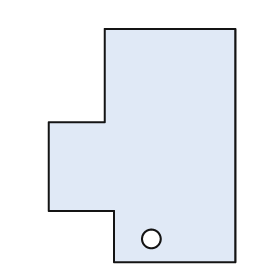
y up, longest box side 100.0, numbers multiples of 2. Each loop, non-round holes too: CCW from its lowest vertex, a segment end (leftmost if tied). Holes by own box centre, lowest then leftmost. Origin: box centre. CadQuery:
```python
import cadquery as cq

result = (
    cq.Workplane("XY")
    .moveTo(-12.0, -50.0)
    .lineTo(40.0, -50.0)
    .lineTo(40.0, 50.0)
    .lineTo(-16.0, 50.0)
    .lineTo(-16.0, 10.0)
    .lineTo(-40.0, 10.0)
    .lineTo(-40.0, -28.0)
    .lineTo(-12.0, -28.0)
    .close()
    .moveTo(4.0, -40.0)
    .circle(4.0)
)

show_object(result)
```